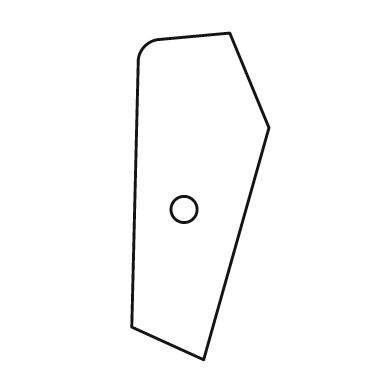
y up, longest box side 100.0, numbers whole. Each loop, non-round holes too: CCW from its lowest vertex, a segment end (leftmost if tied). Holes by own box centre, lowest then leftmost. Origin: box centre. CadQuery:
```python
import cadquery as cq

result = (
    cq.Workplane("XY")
    .moveTo(1.0, -50.0)
    .lineTo(21.0, 21.0)
    .lineTo(9.0, 50.0)
    .lineTo(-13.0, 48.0)
    .threePointArc((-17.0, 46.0), (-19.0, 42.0))
    .lineTo(-21.0, -40.0)
    .close()
    .moveTo(-5.0, -4.0)
    .circle(4.0)
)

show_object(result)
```